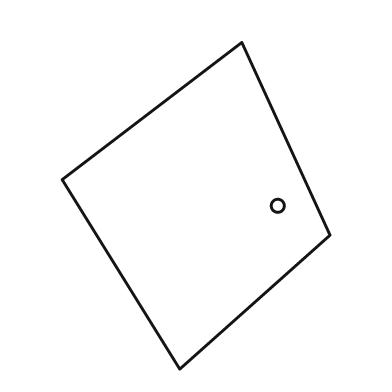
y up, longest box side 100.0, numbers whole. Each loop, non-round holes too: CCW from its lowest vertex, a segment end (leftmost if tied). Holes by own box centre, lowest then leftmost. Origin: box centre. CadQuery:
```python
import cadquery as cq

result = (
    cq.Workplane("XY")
    .moveTo(-5.0, -50.0)
    .lineTo(41.0, -9.0)
    .lineTo(14.0, 50.0)
    .lineTo(-41.0, 8.0)
    .close()
    .moveTo(25.0, 0.0)
    .circle(2.0)
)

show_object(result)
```